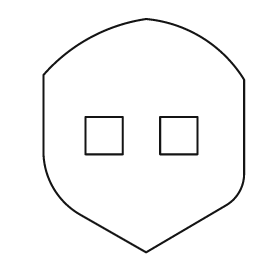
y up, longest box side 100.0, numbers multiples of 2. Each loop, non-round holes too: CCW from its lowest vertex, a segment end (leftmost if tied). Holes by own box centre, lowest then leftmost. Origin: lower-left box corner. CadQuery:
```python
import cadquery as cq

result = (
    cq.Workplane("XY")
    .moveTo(44.0, 0.0)
    .lineTo(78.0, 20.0)
    .threePointArc((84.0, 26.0), (86.0, 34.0))
    .lineTo(86.0, 74.0)
    .threePointArc((68.0, 92.0), (44.0, 100.0))
    .threePointArc((20.0, 92.0), (0.0, 76.0))
    .lineTo(0.0, 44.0)
    .threePointArc((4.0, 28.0), (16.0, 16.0))
    .close()
    .moveTo(18.0, 42.0)
    .lineTo(34.0, 42.0)
    .lineTo(34.0, 58.0)
    .lineTo(18.0, 58.0)
    .close()
    .moveTo(50.0, 42.0)
    .lineTo(66.0, 42.0)
    .lineTo(66.0, 58.0)
    .lineTo(50.0, 58.0)
    .close()
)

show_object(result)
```